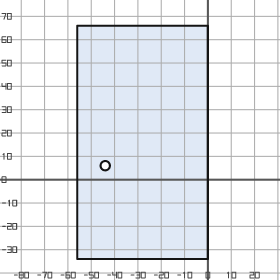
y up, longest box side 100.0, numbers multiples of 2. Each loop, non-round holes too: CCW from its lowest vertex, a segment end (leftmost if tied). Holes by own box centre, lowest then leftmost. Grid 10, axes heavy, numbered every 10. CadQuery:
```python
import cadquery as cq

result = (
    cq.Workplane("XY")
    .moveTo(-56.0, -34.0)
    .lineTo(0.0, -34.0)
    .lineTo(0.0, 66.0)
    .lineTo(-56.0, 66.0)
    .close()
    .moveTo(-44.0, 6.0)
    .circle(2.0)
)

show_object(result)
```